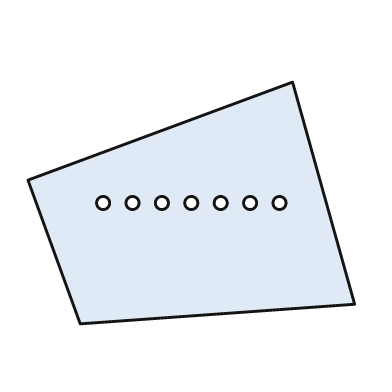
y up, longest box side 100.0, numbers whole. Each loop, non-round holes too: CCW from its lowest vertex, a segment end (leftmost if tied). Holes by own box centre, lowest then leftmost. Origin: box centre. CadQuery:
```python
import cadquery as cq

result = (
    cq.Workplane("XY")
    .moveTo(-34.0, -37.0)
    .lineTo(50.0, -31.0)
    .lineTo(31.0, 37.0)
    .lineTo(-50.0, 7.0)
    .close()
    .moveTo(-27.0, 0.0)
    .circle(2.0)
    .moveTo(-18.0, 0.0)
    .circle(2.0)
    .moveTo(-9.0, 0.0)
    .circle(2.0)
    .moveTo(0.0, 0.0)
    .circle(2.0)
    .moveTo(9.0, 0.0)
    .circle(2.0)
    .moveTo(18.0, 0.0)
    .circle(2.0)
    .moveTo(27.0, 0.0)
    .circle(2.0)
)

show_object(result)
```